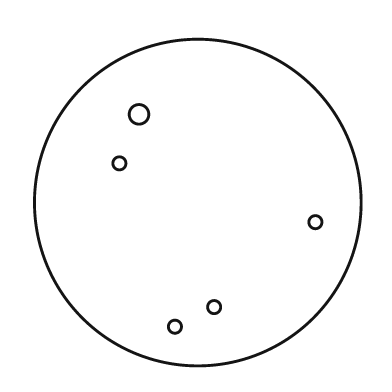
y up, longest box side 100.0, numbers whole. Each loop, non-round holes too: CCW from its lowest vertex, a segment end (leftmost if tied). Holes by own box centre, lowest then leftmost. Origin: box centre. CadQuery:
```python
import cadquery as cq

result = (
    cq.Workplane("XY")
    .moveTo(0.0, 0.0)
    .circle(50.0)
    .moveTo(-7.0, -38.0)
    .circle(2.0)
    .moveTo(5.0, -32.0)
    .circle(2.0)
    .moveTo(36.0, -6.0)
    .circle(2.0)
    .moveTo(-24.0, 12.0)
    .circle(2.0)
    .moveTo(-18.0, 27.0)
    .circle(3.0)
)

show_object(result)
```